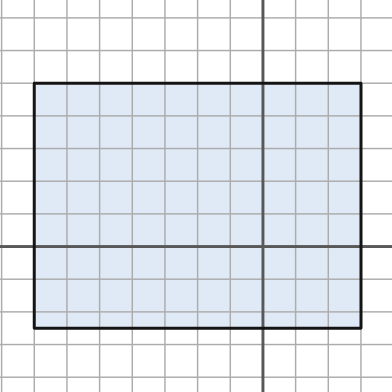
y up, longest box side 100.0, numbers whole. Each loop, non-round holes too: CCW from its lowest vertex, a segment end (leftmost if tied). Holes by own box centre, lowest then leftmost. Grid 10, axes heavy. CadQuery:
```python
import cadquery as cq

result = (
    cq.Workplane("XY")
    .moveTo(-70.0, -25.0)
    .lineTo(30.0, -25.0)
    .lineTo(30.0, 50.0)
    .lineTo(-70.0, 50.0)
    .close()
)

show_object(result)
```